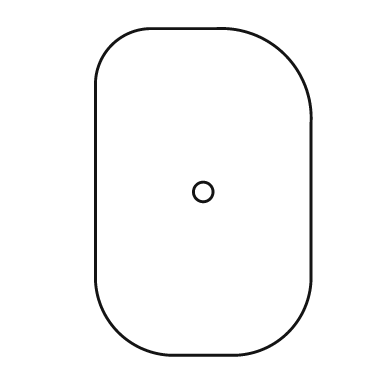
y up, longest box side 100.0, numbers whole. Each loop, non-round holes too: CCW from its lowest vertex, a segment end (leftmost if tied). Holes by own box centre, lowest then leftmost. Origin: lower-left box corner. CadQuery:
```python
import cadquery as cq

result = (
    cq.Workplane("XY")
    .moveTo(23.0, 0.0)
    .lineTo(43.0, 0.0)
    .threePointArc((59.0, 7.0), (66.0, 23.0))
    .lineTo(66.0, 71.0)
    .threePointArc((58.0, 92.0), (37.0, 100.0))
    .lineTo(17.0, 100.0)
    .threePointArc((5.0, 95.0), (0.0, 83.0))
    .lineTo(0.0, 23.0)
    .threePointArc((7.0, 7.0), (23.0, 0.0))
    .close()
    .moveTo(33.0, 50.0)
    .circle(3.0)
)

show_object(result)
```